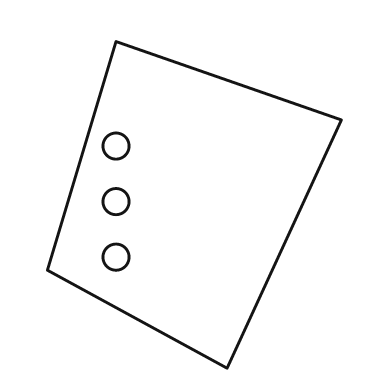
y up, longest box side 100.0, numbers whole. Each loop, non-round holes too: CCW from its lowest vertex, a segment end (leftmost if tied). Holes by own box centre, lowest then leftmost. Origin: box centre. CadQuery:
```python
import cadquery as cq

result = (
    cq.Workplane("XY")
    .moveTo(10.0, -50.0)
    .lineTo(45.0, 26.0)
    .lineTo(-24.0, 50.0)
    .lineTo(-45.0, -20.0)
    .close()
    .moveTo(-24.0, -16.0)
    .circle(4.0)
    .moveTo(-24.0, 1.0)
    .circle(4.0)
    .moveTo(-24.0, 18.0)
    .circle(4.0)
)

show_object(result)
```